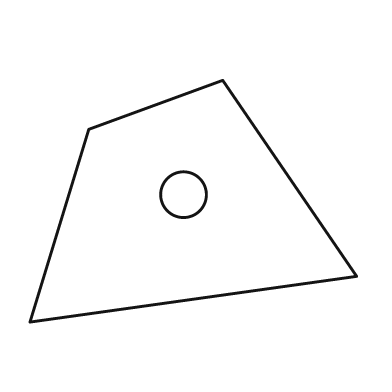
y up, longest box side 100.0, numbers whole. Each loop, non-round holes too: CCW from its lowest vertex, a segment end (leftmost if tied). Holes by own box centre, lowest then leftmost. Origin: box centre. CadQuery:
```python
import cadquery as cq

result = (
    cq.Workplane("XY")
    .moveTo(-50.0, -37.0)
    .lineTo(50.0, -23.0)
    .lineTo(9.0, 37.0)
    .lineTo(-32.0, 22.0)
    .close()
    .moveTo(-3.0, 2.0)
    .circle(7.0)
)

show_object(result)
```